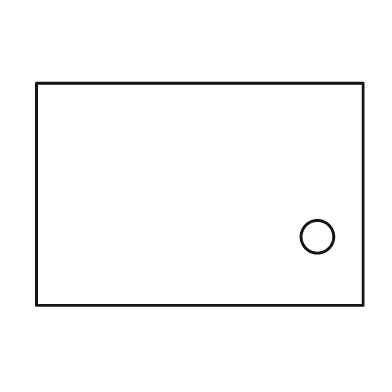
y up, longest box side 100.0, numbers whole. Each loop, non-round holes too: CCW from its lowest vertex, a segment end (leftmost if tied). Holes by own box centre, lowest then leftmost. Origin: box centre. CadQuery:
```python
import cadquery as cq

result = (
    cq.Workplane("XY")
    .moveTo(-50.0, -34.0)
    .lineTo(50.0, -34.0)
    .lineTo(50.0, 34.0)
    .lineTo(-50.0, 34.0)
    .close()
    .moveTo(36.0, -13.0)
    .circle(5.0)
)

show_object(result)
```